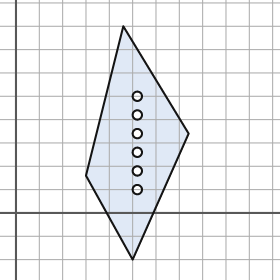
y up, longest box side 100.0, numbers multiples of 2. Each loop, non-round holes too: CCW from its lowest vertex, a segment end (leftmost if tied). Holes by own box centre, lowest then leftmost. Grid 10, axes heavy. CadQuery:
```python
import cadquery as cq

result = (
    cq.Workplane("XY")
    .moveTo(50.0, -20.0)
    .lineTo(74.0, 34.0)
    .lineTo(46.0, 80.0)
    .lineTo(30.0, 16.0)
    .close()
    .moveTo(52.0, 10.0)
    .circle(2.0)
    .moveTo(52.0, 18.0)
    .circle(2.0)
    .moveTo(52.0, 26.0)
    .circle(2.0)
    .moveTo(52.0, 34.0)
    .circle(2.0)
    .moveTo(52.0, 42.0)
    .circle(2.0)
    .moveTo(52.0, 50.0)
    .circle(2.0)
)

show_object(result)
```